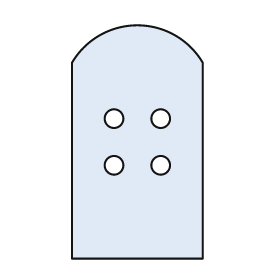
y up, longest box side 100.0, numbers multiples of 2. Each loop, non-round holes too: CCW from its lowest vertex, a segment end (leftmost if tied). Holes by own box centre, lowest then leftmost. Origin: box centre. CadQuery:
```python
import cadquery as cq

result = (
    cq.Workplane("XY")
    .moveTo(-28.0, -50.0)
    .lineTo(28.0, -50.0)
    .lineTo(28.0, 34.0)
    .threePointArc((0.0, 50.0), (-28.0, 34.0))
    .close()
    .moveTo(-10.0, -10.0)
    .circle(4.0)
    .moveTo(10.0, -10.0)
    .circle(4.0)
    .moveTo(-10.0, 10.0)
    .circle(4.0)
    .moveTo(10.0, 10.0)
    .circle(4.0)
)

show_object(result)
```